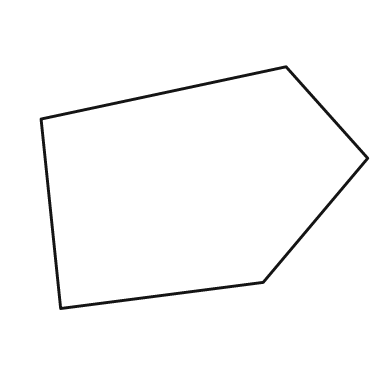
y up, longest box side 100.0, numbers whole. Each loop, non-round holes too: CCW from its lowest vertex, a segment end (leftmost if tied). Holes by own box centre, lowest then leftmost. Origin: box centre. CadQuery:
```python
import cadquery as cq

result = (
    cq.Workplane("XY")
    .moveTo(-44.0, -37.0)
    .lineTo(18.0, -29.0)
    .lineTo(50.0, 9.0)
    .lineTo(25.0, 37.0)
    .lineTo(-50.0, 21.0)
    .close()
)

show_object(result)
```